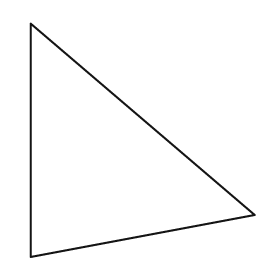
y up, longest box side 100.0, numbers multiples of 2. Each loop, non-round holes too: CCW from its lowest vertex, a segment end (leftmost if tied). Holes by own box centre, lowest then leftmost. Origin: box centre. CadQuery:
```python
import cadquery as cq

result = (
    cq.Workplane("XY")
    .moveTo(-48.0, -50.0)
    .lineTo(48.0, -32.0)
    .lineTo(-48.0, 50.0)
    .close()
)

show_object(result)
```